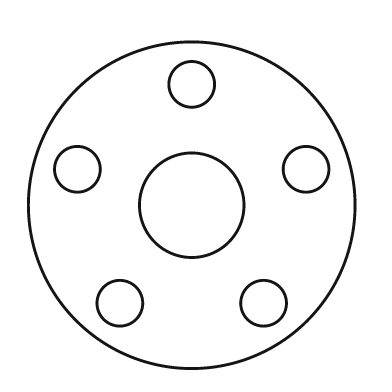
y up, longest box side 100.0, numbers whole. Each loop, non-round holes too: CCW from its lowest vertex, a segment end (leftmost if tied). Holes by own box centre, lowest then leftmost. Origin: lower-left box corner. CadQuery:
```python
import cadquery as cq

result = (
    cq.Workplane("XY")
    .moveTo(50.0, 50.0)
    .circle(50.0)
    .moveTo(28.0, 20.0)
    .circle(7.0)
    .moveTo(72.0, 20.0)
    .circle(7.0)
    .moveTo(50.0, 50.0)
    .circle(16.0)
    .moveTo(15.0, 61.0)
    .circle(7.0)
    .moveTo(85.0, 61.0)
    .circle(7.0)
    .moveTo(50.0, 87.0)
    .circle(7.0)
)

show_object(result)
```